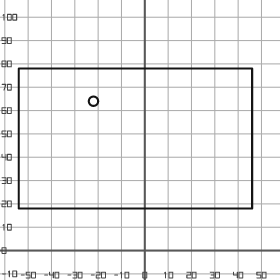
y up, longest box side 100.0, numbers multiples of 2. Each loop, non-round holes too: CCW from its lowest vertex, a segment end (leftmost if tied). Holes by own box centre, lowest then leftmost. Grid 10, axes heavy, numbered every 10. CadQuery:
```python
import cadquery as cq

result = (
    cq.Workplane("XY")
    .moveTo(-54.0, 18.0)
    .lineTo(46.0, 18.0)
    .lineTo(46.0, 78.0)
    .lineTo(-54.0, 78.0)
    .close()
    .moveTo(-22.0, 64.0)
    .circle(2.0)
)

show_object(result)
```